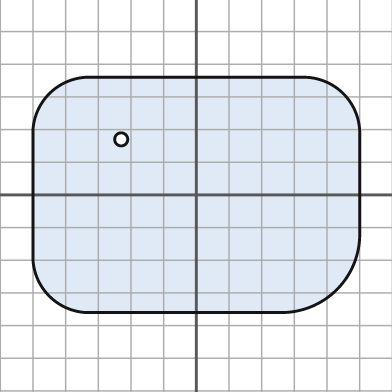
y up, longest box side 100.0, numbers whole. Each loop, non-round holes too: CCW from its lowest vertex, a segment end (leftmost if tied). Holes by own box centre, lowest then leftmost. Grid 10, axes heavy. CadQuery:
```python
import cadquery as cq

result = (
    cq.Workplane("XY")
    .moveTo(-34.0, -36.0)
    .lineTo(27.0, -36.0)
    .threePointArc((43.0, -29.0), (50.0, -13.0))
    .lineTo(50.0, 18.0)
    .threePointArc((45.0, 31.0), (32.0, 36.0))
    .lineTo(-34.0, 36.0)
    .threePointArc((-45.0, 31.0), (-50.0, 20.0))
    .lineTo(-50.0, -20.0)
    .threePointArc((-45.0, -31.0), (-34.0, -36.0))
    .close()
    .moveTo(-23.0, 17.0)
    .circle(2.0)
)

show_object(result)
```